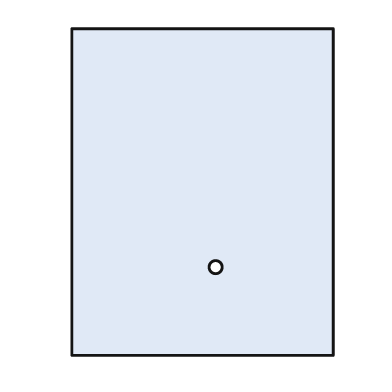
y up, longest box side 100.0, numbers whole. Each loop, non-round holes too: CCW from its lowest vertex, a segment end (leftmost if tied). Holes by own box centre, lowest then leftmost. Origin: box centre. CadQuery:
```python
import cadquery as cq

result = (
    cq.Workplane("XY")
    .moveTo(-40.0, -50.0)
    .lineTo(40.0, -50.0)
    .lineTo(40.0, 50.0)
    .lineTo(-40.0, 50.0)
    .close()
    .moveTo(4.0, -23.0)
    .circle(2.0)
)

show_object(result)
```